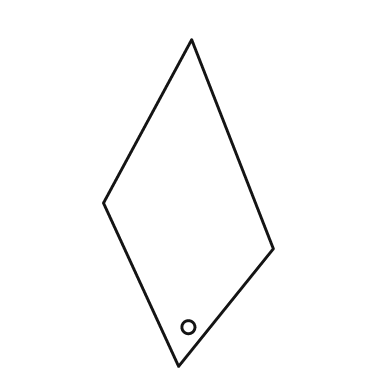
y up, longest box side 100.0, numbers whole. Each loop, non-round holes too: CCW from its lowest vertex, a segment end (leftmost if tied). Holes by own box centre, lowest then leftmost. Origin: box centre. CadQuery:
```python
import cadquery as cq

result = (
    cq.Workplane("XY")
    .moveTo(-3.0, -50.0)
    .lineTo(26.0, -14.0)
    .lineTo(1.0, 50.0)
    .lineTo(-26.0, 0.0)
    .close()
    .moveTo(0.0, -38.0)
    .circle(2.0)
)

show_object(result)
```